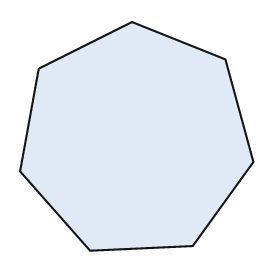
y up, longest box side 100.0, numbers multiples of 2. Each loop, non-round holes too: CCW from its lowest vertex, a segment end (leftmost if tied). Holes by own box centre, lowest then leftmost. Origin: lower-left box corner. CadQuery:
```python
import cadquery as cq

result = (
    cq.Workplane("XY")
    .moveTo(30.0, 0.0)
    .lineTo(74.0, 2.0)
    .lineTo(100.0, 38.0)
    .lineTo(88.0, 82.0)
    .lineTo(48.0, 98.0)
    .lineTo(8.0, 78.0)
    .lineTo(0.0, 34.0)
    .close()
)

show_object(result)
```